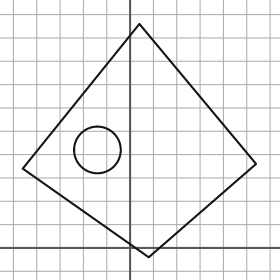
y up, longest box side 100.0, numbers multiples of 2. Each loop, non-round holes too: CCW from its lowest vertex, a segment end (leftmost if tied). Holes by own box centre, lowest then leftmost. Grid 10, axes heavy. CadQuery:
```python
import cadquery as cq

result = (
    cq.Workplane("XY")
    .moveTo(8.0, -4.0)
    .lineTo(54.0, 36.0)
    .lineTo(4.0, 96.0)
    .lineTo(-46.0, 34.0)
    .close()
    .moveTo(-14.0, 42.0)
    .circle(10.0)
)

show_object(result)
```